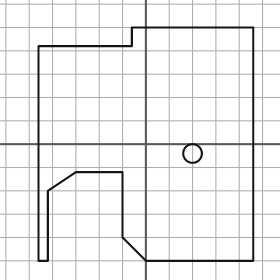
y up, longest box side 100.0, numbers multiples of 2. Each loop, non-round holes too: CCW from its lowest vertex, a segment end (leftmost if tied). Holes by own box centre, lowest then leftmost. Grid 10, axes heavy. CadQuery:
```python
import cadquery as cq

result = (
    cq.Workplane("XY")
    .moveTo(-46.0, -50.0)
    .lineTo(-42.0, -50.0)
    .lineTo(-42.0, -20.0)
    .lineTo(-30.0, -12.0)
    .lineTo(-10.0, -12.0)
    .lineTo(-10.0, -40.0)
    .lineTo(0.0, -50.0)
    .lineTo(46.0, -50.0)
    .lineTo(46.0, 50.0)
    .lineTo(-6.0, 50.0)
    .lineTo(-6.0, 42.0)
    .lineTo(-46.0, 42.0)
    .close()
    .moveTo(20.0, -4.0)
    .circle(4.0)
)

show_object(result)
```